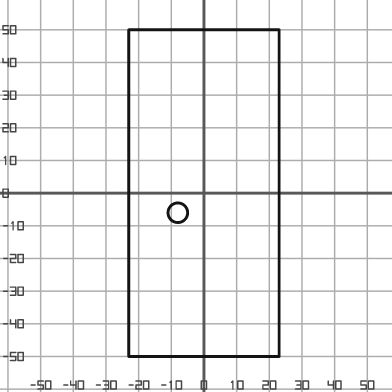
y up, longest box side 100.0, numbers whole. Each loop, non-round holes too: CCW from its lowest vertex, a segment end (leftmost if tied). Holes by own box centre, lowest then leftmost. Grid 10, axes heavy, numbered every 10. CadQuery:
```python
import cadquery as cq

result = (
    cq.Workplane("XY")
    .moveTo(-23.0, -50.0)
    .lineTo(23.0, -50.0)
    .lineTo(23.0, 50.0)
    .lineTo(-23.0, 50.0)
    .close()
    .moveTo(-8.0, -6.0)
    .circle(3.0)
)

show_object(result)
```